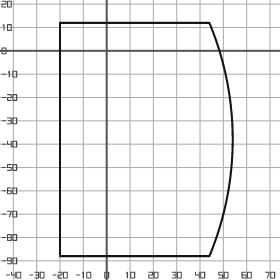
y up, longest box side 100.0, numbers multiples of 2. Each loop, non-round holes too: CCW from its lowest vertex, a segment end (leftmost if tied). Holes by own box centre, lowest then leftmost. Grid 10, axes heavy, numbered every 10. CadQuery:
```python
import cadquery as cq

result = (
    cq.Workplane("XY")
    .moveTo(-20.0, -88.0)
    .lineTo(44.0, -88.0)
    .threePointArc((54.0, -38.0), (44.0, 12.0))
    .lineTo(-20.0, 12.0)
    .close()
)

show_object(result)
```